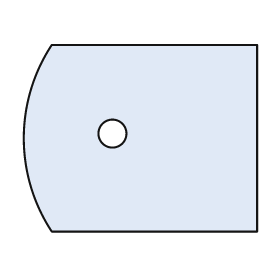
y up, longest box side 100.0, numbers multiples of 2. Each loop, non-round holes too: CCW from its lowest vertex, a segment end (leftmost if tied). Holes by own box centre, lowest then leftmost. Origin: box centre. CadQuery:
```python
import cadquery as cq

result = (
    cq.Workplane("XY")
    .moveTo(-38.0, -40.0)
    .lineTo(50.0, -40.0)
    .lineTo(50.0, 40.0)
    .lineTo(-38.0, 40.0)
    .threePointArc((-50.0, 0.0), (-38.0, -40.0))
    .close()
    .moveTo(-12.0, 2.0)
    .circle(6.0)
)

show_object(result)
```